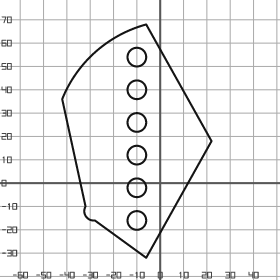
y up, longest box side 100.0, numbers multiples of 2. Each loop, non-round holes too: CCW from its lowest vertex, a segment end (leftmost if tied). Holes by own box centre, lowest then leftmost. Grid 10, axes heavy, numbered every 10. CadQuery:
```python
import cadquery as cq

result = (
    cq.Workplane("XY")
    .moveTo(-6.0, -32.0)
    .lineTo(22.0, 18.0)
    .lineTo(-6.0, 68.0)
    .threePointArc((-28.0, 56.0), (-42.0, 36.0))
    .lineTo(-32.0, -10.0)
    .threePointArc((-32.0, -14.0), (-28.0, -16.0))
    .close()
    .moveTo(-10.0, -16.0)
    .circle(4.0)
    .moveTo(-10.0, -2.0)
    .circle(4.0)
    .moveTo(-10.0, 12.0)
    .circle(4.0)
    .moveTo(-10.0, 26.0)
    .circle(4.0)
    .moveTo(-10.0, 40.0)
    .circle(4.0)
    .moveTo(-10.0, 54.0)
    .circle(4.0)
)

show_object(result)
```